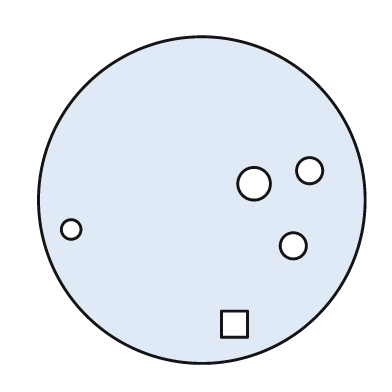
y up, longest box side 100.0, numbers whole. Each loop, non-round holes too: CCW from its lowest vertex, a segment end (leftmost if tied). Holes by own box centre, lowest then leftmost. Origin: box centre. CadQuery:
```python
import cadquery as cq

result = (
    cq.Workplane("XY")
    .moveTo(0.0, 0.0)
    .circle(50.0)
    .moveTo(6.0, -42.0)
    .lineTo(14.0, -42.0)
    .lineTo(14.0, -34.0)
    .lineTo(6.0, -34.0)
    .close()
    .moveTo(28.0, -14.0)
    .circle(4.0)
    .moveTo(-40.0, -9.0)
    .circle(3.0)
    .moveTo(16.0, 5.0)
    .circle(5.0)
    .moveTo(33.0, 9.0)
    .circle(4.0)
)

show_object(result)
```